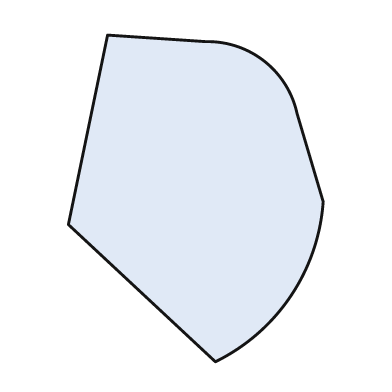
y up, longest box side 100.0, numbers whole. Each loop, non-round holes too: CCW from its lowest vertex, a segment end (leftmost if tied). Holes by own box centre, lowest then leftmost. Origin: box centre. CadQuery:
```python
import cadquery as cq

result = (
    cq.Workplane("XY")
    .moveTo(6.0, -50.0)
    .threePointArc((29.0, -30.0), (39.0, -1.0))
    .lineTo(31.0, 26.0)
    .threePointArc((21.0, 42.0), (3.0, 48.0))
    .lineTo(-27.0, 50.0)
    .lineTo(-39.0, -8.0)
    .close()
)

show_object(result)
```